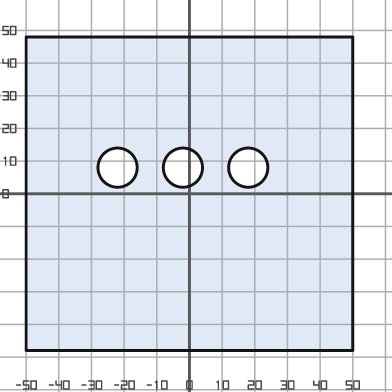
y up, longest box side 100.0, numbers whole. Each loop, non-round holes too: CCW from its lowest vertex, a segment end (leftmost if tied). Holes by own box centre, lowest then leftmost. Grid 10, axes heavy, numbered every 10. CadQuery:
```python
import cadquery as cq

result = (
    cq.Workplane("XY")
    .moveTo(-50.0, -48.0)
    .lineTo(50.0, -48.0)
    .lineTo(50.0, 48.0)
    .lineTo(-50.0, 48.0)
    .close()
    .moveTo(-22.0, 8.0)
    .circle(6.0)
    .moveTo(-2.0, 8.0)
    .circle(6.0)
    .moveTo(18.0, 8.0)
    .circle(6.0)
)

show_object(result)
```